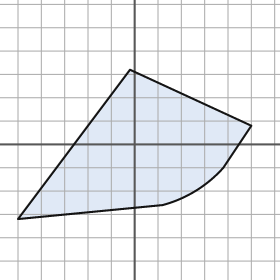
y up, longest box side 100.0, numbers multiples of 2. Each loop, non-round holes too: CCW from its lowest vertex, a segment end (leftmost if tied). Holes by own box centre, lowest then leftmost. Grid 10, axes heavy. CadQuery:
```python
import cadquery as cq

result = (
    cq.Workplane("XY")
    .moveTo(-50.0, -32.0)
    .lineTo(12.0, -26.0)
    .threePointArc((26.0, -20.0), (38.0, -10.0))
    .lineTo(50.0, 8.0)
    .lineTo(-2.0, 32.0)
    .close()
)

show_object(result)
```